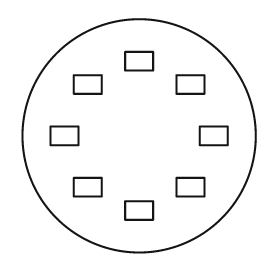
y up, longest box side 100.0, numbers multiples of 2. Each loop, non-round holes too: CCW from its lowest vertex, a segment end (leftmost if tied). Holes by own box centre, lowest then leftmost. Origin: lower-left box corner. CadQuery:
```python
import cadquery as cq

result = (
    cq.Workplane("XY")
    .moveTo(50.0, 50.0)
    .circle(50.0)
    .moveTo(44.0, 14.0)
    .lineTo(56.0, 14.0)
    .lineTo(56.0, 22.0)
    .lineTo(44.0, 22.0)
    .close()
    .moveTo(22.0, 24.0)
    .lineTo(34.0, 24.0)
    .lineTo(34.0, 32.0)
    .lineTo(22.0, 32.0)
    .close()
    .moveTo(66.0, 24.0)
    .lineTo(78.0, 24.0)
    .lineTo(78.0, 32.0)
    .lineTo(66.0, 32.0)
    .close()
    .moveTo(12.0, 46.0)
    .lineTo(24.0, 46.0)
    .lineTo(24.0, 54.0)
    .lineTo(12.0, 54.0)
    .close()
    .moveTo(76.0, 46.0)
    .lineTo(88.0, 46.0)
    .lineTo(88.0, 54.0)
    .lineTo(76.0, 54.0)
    .close()
    .moveTo(22.0, 68.0)
    .lineTo(34.0, 68.0)
    .lineTo(34.0, 76.0)
    .lineTo(22.0, 76.0)
    .close()
    .moveTo(66.0, 68.0)
    .lineTo(78.0, 68.0)
    .lineTo(78.0, 76.0)
    .lineTo(66.0, 76.0)
    .close()
    .moveTo(44.0, 78.0)
    .lineTo(56.0, 78.0)
    .lineTo(56.0, 86.0)
    .lineTo(44.0, 86.0)
    .close()
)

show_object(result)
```